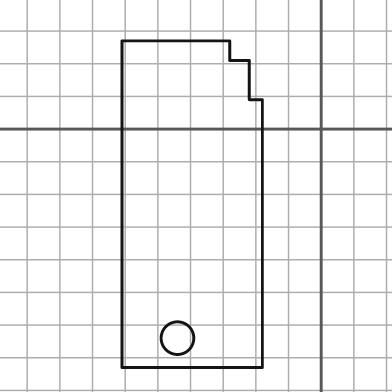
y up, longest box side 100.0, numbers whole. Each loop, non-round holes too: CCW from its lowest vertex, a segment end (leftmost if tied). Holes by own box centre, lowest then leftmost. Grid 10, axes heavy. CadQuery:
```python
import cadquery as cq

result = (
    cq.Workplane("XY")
    .moveTo(-61.0, -73.0)
    .lineTo(-18.0, -73.0)
    .lineTo(-18.0, 9.0)
    .lineTo(-22.0, 9.0)
    .lineTo(-22.0, 21.0)
    .lineTo(-28.0, 21.0)
    .lineTo(-28.0, 27.0)
    .lineTo(-61.0, 27.0)
    .close()
    .moveTo(-44.0, -64.0)
    .circle(5.0)
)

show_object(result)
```